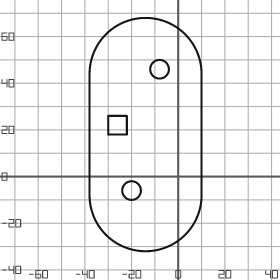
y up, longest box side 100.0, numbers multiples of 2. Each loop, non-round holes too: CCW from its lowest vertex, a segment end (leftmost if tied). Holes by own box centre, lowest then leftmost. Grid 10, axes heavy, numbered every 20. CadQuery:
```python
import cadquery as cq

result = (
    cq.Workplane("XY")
    .moveTo(-38.0, -8.0)
    .threePointArc((-14.0, -32.0), (10.0, -8.0))
    .lineTo(10.0, 44.0)
    .threePointArc((-14.0, 68.0), (-38.0, 44.0))
    .close()
    .moveTo(-20.0, -6.0)
    .circle(4.0)
    .moveTo(-30.0, 18.0)
    .lineTo(-22.0, 18.0)
    .lineTo(-22.0, 26.0)
    .lineTo(-30.0, 26.0)
    .close()
    .moveTo(-8.0, 46.0)
    .circle(4.0)
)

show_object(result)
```